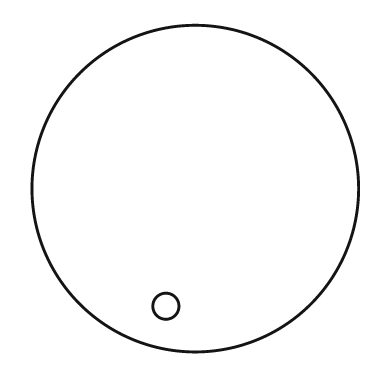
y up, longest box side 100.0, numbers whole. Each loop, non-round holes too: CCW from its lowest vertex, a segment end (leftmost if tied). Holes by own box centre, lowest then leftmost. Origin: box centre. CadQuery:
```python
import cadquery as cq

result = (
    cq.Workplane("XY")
    .moveTo(0.0, 0.0)
    .circle(50.0)
    .moveTo(-9.0, -36.0)
    .circle(4.0)
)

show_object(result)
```